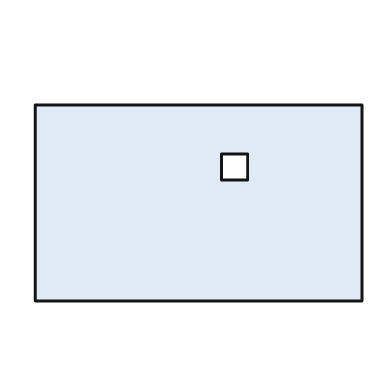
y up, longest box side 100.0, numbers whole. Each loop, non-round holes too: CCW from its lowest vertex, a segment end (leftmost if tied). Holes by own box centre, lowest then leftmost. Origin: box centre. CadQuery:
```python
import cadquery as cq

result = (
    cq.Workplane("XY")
    .moveTo(-50.0, -30.0)
    .lineTo(50.0, -30.0)
    .lineTo(50.0, 30.0)
    .lineTo(-50.0, 30.0)
    .close()
    .moveTo(7.0, 7.0)
    .lineTo(15.0, 7.0)
    .lineTo(15.0, 15.0)
    .lineTo(7.0, 15.0)
    .close()
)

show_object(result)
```